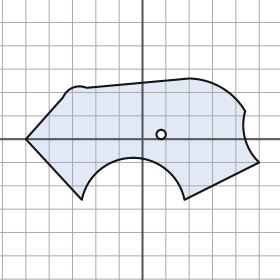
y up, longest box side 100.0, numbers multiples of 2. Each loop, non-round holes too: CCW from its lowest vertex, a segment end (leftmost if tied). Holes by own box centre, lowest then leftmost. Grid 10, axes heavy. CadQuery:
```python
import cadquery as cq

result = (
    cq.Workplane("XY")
    .moveTo(-26.0, -26.0)
    .threePointArc((-4.0, -8.0), (18.0, -26.0))
    .lineTo(50.0, -10.0)
    .threePointArc((44.0, 0.0), (44.0, 12.0))
    .threePointArc((34.0, 22.0), (20.0, 26.0))
    .lineTo(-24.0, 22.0)
    .threePointArc((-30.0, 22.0), (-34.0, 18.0))
    .lineTo(-50.0, 0.0)
    .close()
    .moveTo(8.0, 2.0)
    .circle(2.0)
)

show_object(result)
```